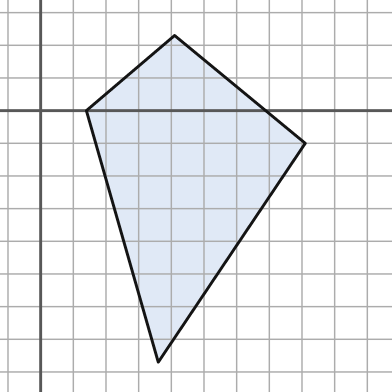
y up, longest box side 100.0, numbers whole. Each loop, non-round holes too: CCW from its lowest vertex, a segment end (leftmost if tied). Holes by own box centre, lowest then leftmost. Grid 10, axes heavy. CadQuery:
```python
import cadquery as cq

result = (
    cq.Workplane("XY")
    .moveTo(36.0, -77.0)
    .lineTo(81.0, -10.0)
    .lineTo(41.0, 23.0)
    .lineTo(14.0, 0.0)
    .close()
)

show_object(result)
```